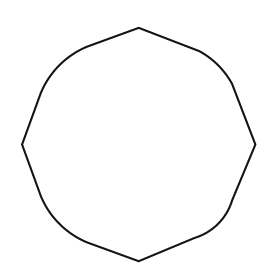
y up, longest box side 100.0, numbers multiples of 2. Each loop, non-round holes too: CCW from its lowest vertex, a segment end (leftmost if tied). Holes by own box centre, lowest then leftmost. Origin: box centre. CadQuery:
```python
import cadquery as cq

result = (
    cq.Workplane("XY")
    .moveTo(0.0, -50.0)
    .lineTo(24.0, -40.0)
    .threePointArc((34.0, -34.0), (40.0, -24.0))
    .lineTo(50.0, 0.0)
    .lineTo(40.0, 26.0)
    .threePointArc((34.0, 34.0), (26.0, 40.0))
    .lineTo(0.0, 50.0)
    .lineTo(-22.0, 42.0)
    .threePointArc((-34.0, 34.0), (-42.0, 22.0))
    .lineTo(-50.0, 0.0)
    .lineTo(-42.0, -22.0)
    .threePointArc((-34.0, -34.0), (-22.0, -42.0))
    .close()
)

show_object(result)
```